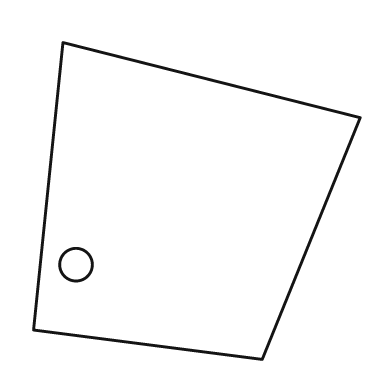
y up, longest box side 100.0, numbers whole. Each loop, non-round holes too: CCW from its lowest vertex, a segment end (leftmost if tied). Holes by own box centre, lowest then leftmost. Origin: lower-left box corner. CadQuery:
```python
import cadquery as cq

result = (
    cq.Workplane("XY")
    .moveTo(70.0, 0.0)
    .lineTo(100.0, 74.0)
    .lineTo(9.0, 97.0)
    .lineTo(0.0, 9.0)
    .close()
    .moveTo(13.0, 29.0)
    .circle(5.0)
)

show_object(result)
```